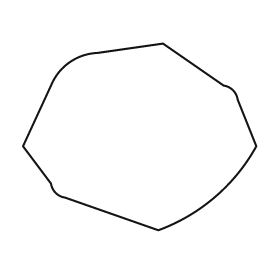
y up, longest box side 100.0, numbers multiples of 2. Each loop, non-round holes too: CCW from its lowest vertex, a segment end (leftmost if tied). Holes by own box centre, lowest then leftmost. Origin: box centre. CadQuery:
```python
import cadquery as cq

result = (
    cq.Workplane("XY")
    .moveTo(8.0, -40.0)
    .threePointArc((32.0, -26.0), (50.0, -4.0))
    .lineTo(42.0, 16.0)
    .threePointArc((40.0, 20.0), (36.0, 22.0))
    .lineTo(10.0, 40.0)
    .lineTo(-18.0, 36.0)
    .threePointArc((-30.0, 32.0), (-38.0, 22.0))
    .lineTo(-50.0, -4.0)
    .lineTo(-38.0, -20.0)
    .threePointArc((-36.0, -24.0), (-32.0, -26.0))
    .close()
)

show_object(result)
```